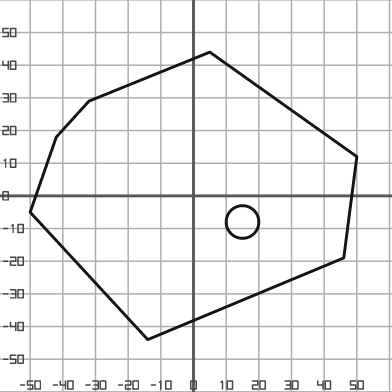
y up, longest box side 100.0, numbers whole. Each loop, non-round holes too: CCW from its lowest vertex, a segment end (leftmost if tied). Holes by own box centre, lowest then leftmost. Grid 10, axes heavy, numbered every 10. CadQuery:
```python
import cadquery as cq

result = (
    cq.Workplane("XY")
    .moveTo(-14.0, -44.0)
    .lineTo(46.0, -19.0)
    .lineTo(50.0, 12.0)
    .lineTo(5.0, 44.0)
    .lineTo(-32.0, 29.0)
    .lineTo(-42.0, 18.0)
    .lineTo(-50.0, -5.0)
    .close()
    .moveTo(15.0, -8.0)
    .circle(5.0)
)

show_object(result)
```